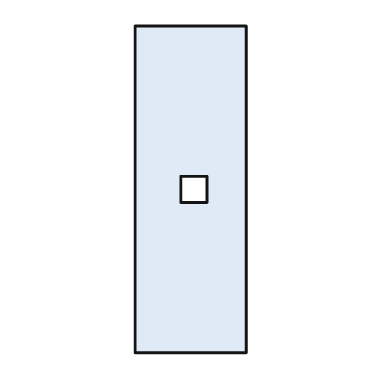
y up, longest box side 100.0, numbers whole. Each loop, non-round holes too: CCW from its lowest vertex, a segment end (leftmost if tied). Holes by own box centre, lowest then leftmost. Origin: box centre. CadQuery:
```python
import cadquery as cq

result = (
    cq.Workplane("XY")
    .moveTo(-17.0, -50.0)
    .lineTo(17.0, -50.0)
    .lineTo(17.0, 50.0)
    .lineTo(-17.0, 50.0)
    .close()
    .moveTo(-3.0, -4.0)
    .lineTo(5.0, -4.0)
    .lineTo(5.0, 4.0)
    .lineTo(-3.0, 4.0)
    .close()
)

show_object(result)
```